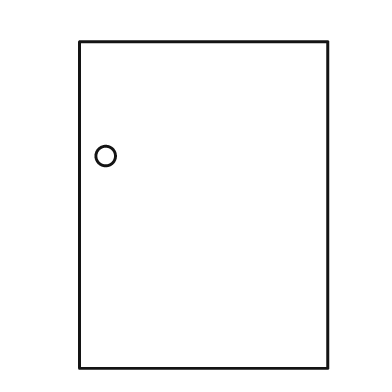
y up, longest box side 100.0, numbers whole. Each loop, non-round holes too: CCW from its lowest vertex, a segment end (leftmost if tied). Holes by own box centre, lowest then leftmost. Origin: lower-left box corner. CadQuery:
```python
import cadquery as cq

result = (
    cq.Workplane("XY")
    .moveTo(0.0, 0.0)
    .lineTo(76.0, 0.0)
    .lineTo(76.0, 100.0)
    .lineTo(0.0, 100.0)
    .close()
    .moveTo(8.0, 65.0)
    .circle(3.0)
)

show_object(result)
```